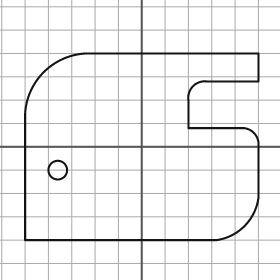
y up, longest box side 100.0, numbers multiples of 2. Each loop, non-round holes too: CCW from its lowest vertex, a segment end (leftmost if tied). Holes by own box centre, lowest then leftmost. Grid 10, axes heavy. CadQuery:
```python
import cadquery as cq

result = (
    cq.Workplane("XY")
    .moveTo(-50.0, -40.0)
    .lineTo(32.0, -40.0)
    .threePointArc((44.0, -34.0), (50.0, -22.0))
    .lineTo(50.0, 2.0)
    .threePointArc((48.0, 6.0), (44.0, 8.0))
    .lineTo(20.0, 8.0)
    .lineTo(20.0, 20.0)
    .threePointArc((22.0, 26.0), (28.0, 28.0))
    .lineTo(50.0, 28.0)
    .lineTo(50.0, 40.0)
    .lineTo(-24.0, 40.0)
    .threePointArc((-42.0, 32.0), (-50.0, 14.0))
    .close()
    .moveTo(-36.0, -10.0)
    .circle(4.0)
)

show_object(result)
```